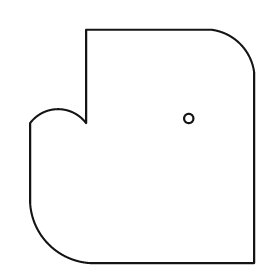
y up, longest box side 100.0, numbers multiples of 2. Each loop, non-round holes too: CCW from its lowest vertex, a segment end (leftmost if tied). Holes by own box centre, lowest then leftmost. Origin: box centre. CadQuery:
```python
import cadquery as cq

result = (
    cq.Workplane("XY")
    .moveTo(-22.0, -50.0)
    .lineTo(48.0, -50.0)
    .lineTo(48.0, 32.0)
    .threePointArc((42.0, 44.0), (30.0, 50.0))
    .lineTo(-24.0, 50.0)
    .lineTo(-24.0, 10.0)
    .threePointArc((-36.0, 16.0), (-48.0, 10.0))
    .lineTo(-48.0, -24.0)
    .threePointArc((-40.0, -42.0), (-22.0, -50.0))
    .close()
    .moveTo(20.0, 12.0)
    .circle(2.0)
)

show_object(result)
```